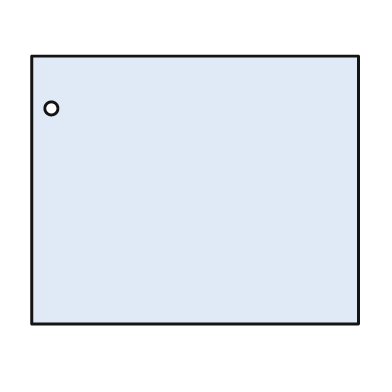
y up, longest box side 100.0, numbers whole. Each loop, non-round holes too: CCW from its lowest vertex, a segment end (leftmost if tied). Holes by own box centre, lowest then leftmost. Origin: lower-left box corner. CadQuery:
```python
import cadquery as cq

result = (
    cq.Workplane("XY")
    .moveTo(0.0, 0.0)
    .lineTo(100.0, 0.0)
    .lineTo(100.0, 82.0)
    .lineTo(0.0, 82.0)
    .close()
    .moveTo(6.0, 66.0)
    .circle(2.0)
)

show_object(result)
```